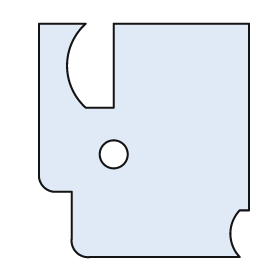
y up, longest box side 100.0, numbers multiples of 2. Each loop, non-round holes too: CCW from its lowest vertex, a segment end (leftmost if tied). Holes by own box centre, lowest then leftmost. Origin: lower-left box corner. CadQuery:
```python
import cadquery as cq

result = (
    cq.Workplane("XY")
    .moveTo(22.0, 0.0)
    .lineTo(86.0, 0.0)
    .threePointArc((82.0, 10.0), (86.0, 20.0))
    .lineTo(90.0, 20.0)
    .lineTo(90.0, 100.0)
    .lineTo(32.0, 100.0)
    .lineTo(32.0, 64.0)
    .lineTo(20.0, 64.0)
    .threePointArc((12.0, 82.0), (20.0, 100.0))
    .lineTo(0.0, 100.0)
    .lineTo(0.0, 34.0)
    .threePointArc((2.0, 30.0), (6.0, 28.0))
    .lineTo(14.0, 28.0)
    .lineTo(14.0, 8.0)
    .threePointArc((16.0, 2.0), (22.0, 0.0))
    .close()
    .moveTo(32.0, 44.0)
    .circle(6.0)
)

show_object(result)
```